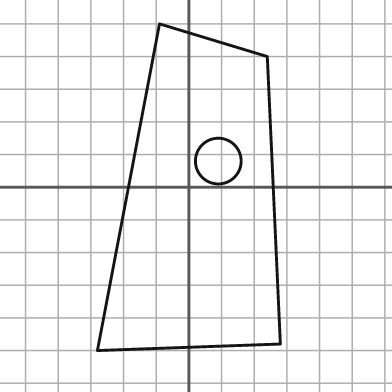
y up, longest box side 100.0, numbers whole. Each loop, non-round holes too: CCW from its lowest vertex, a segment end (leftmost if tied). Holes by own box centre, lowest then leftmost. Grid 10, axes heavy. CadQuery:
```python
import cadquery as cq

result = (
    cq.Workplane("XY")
    .moveTo(-28.0, -50.0)
    .lineTo(28.0, -48.0)
    .lineTo(24.0, 40.0)
    .lineTo(-9.0, 50.0)
    .close()
    .moveTo(9.0, 8.0)
    .circle(7.0)
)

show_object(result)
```